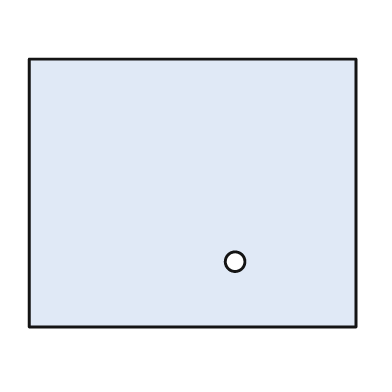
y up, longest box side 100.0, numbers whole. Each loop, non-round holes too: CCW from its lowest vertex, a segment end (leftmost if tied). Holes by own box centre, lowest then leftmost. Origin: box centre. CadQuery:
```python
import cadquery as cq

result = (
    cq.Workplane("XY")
    .moveTo(-50.0, -41.0)
    .lineTo(50.0, -41.0)
    .lineTo(50.0, 41.0)
    .lineTo(-50.0, 41.0)
    .close()
    .moveTo(13.0, -21.0)
    .circle(3.0)
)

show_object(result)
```